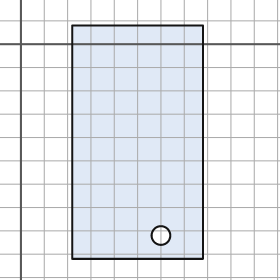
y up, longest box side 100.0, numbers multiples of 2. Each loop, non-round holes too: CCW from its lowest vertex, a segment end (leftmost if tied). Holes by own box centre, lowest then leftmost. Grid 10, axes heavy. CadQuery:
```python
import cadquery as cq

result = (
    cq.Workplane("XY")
    .moveTo(22.0, -92.0)
    .lineTo(78.0, -92.0)
    .lineTo(78.0, 8.0)
    .lineTo(22.0, 8.0)
    .close()
    .moveTo(60.0, -82.0)
    .circle(4.0)
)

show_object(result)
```